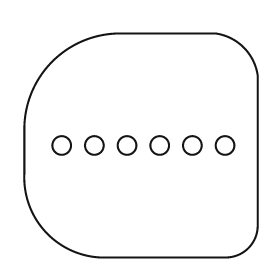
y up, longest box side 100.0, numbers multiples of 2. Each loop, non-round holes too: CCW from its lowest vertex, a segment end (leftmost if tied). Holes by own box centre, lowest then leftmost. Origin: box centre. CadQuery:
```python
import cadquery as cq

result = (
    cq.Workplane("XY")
    .moveTo(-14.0, -48.0)
    .lineTo(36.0, -48.0)
    .threePointArc((46.0, -44.0), (50.0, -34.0))
    .lineTo(50.0, 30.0)
    .threePointArc((44.0, 42.0), (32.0, 48.0))
    .lineTo(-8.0, 48.0)
    .threePointArc((-38.0, 36.0), (-50.0, 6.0))
    .lineTo(-50.0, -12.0)
    .threePointArc((-40.0, -38.0), (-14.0, -48.0))
    .close()
    .moveTo(-34.0, 0.0)
    .circle(4.0)
    .moveTo(-20.0, 0.0)
    .circle(4.0)
    .moveTo(-6.0, 0.0)
    .circle(4.0)
    .moveTo(8.0, 0.0)
    .circle(4.0)
    .moveTo(22.0, 0.0)
    .circle(4.0)
    .moveTo(36.0, 0.0)
    .circle(4.0)
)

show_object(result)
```